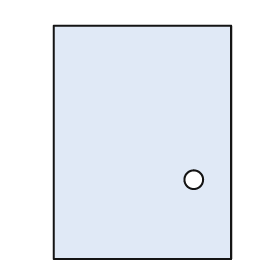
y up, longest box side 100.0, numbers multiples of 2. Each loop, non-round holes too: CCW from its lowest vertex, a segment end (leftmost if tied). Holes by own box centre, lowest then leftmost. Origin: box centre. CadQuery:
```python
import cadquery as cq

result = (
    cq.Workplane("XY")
    .moveTo(-38.0, -50.0)
    .lineTo(38.0, -50.0)
    .lineTo(38.0, 50.0)
    .lineTo(-38.0, 50.0)
    .close()
    .moveTo(22.0, -16.0)
    .circle(4.0)
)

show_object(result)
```